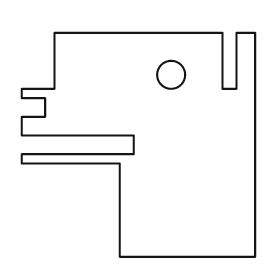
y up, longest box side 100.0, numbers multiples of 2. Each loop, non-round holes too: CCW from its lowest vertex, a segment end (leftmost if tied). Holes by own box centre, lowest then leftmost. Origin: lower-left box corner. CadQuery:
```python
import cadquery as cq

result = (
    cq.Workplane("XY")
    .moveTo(42.0, 0.0)
    .lineTo(100.0, 0.0)
    .lineTo(100.0, 96.0)
    .lineTo(92.0, 96.0)
    .lineTo(92.0, 72.0)
    .lineTo(86.0, 72.0)
    .lineTo(86.0, 96.0)
    .lineTo(14.0, 96.0)
    .lineTo(14.0, 72.0)
    .lineTo(0.0, 72.0)
    .lineTo(0.0, 68.0)
    .lineTo(10.0, 68.0)
    .lineTo(10.0, 60.0)
    .lineTo(0.0, 60.0)
    .lineTo(0.0, 52.0)
    .lineTo(48.0, 52.0)
    .lineTo(48.0, 44.0)
    .lineTo(0.0, 44.0)
    .lineTo(0.0, 40.0)
    .lineTo(42.0, 40.0)
    .close()
    .moveTo(64.0, 78.0)
    .circle(6.0)
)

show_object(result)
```